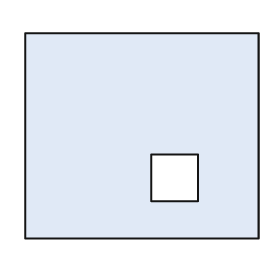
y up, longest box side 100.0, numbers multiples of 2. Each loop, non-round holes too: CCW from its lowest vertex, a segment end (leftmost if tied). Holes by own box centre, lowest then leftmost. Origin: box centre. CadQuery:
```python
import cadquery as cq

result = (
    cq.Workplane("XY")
    .moveTo(-50.0, -44.0)
    .lineTo(50.0, -44.0)
    .lineTo(50.0, 44.0)
    .lineTo(-50.0, 44.0)
    .close()
    .moveTo(4.0, -28.0)
    .lineTo(24.0, -28.0)
    .lineTo(24.0, -8.0)
    .lineTo(4.0, -8.0)
    .close()
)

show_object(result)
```